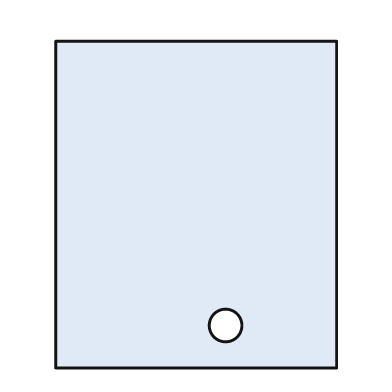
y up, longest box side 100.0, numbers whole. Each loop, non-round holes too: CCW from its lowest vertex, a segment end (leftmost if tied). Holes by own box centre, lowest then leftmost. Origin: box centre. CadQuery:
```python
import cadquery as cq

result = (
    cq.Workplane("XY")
    .moveTo(-43.0, -50.0)
    .lineTo(43.0, -50.0)
    .lineTo(43.0, 50.0)
    .lineTo(-43.0, 50.0)
    .close()
    .moveTo(9.0, -37.0)
    .circle(5.0)
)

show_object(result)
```